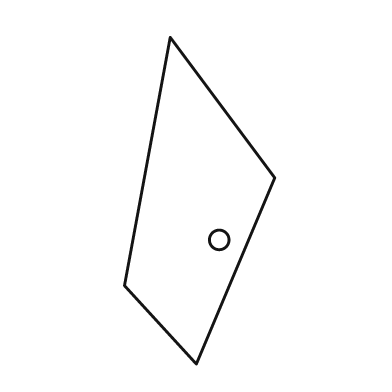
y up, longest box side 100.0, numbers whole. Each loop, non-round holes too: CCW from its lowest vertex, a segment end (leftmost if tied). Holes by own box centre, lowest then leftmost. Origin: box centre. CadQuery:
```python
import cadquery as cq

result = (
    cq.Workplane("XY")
    .moveTo(-1.0, -50.0)
    .lineTo(23.0, 7.0)
    .lineTo(-9.0, 50.0)
    .lineTo(-23.0, -26.0)
    .close()
    .moveTo(6.0, -12.0)
    .circle(3.0)
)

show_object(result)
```